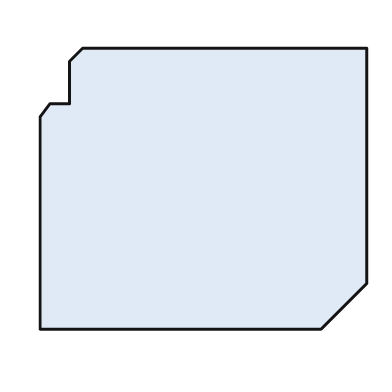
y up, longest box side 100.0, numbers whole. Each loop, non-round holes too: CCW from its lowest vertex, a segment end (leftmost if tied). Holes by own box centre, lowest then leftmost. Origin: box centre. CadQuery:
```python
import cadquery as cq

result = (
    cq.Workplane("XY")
    .moveTo(-50.0, -43.0)
    .lineTo(36.0, -43.0)
    .lineTo(50.0, -29.0)
    .lineTo(50.0, 43.0)
    .lineTo(-37.0, 43.0)
    .lineTo(-41.0, 39.0)
    .lineTo(-41.0, 26.0)
    .lineTo(-47.0, 26.0)
    .lineTo(-50.0, 22.0)
    .close()
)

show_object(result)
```